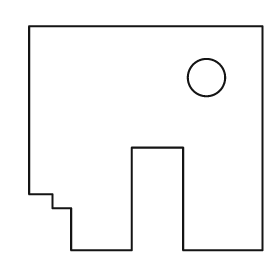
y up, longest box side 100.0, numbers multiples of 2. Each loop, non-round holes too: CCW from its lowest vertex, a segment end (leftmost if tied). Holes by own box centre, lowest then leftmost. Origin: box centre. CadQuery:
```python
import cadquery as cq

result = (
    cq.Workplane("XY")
    .moveTo(-32.0, -48.0)
    .lineTo(-6.0, -48.0)
    .lineTo(-6.0, -4.0)
    .lineTo(16.0, -4.0)
    .lineTo(16.0, -48.0)
    .lineTo(50.0, -48.0)
    .lineTo(50.0, 48.0)
    .lineTo(-50.0, 48.0)
    .lineTo(-50.0, -24.0)
    .lineTo(-40.0, -24.0)
    .lineTo(-40.0, -30.0)
    .lineTo(-32.0, -30.0)
    .close()
    .moveTo(26.0, 26.0)
    .circle(8.0)
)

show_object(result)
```